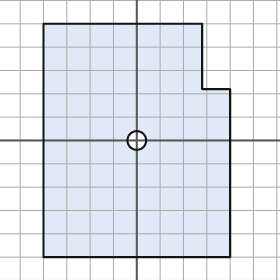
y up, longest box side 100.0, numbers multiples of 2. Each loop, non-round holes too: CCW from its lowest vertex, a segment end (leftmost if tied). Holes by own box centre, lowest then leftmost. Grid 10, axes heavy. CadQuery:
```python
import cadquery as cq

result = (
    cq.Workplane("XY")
    .moveTo(-40.0, -50.0)
    .lineTo(40.0, -50.0)
    .lineTo(40.0, 22.0)
    .lineTo(28.0, 22.0)
    .lineTo(28.0, 50.0)
    .lineTo(-40.0, 50.0)
    .close()
    .moveTo(0.0, 0.0)
    .circle(4.0)
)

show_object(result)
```